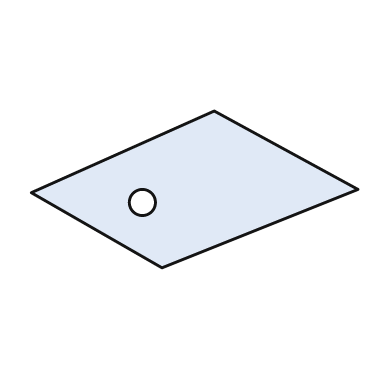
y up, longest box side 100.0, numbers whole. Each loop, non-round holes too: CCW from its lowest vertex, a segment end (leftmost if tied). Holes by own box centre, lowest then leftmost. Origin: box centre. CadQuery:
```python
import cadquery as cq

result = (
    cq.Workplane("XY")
    .moveTo(-10.0, -24.0)
    .lineTo(50.0, 0.0)
    .lineTo(6.0, 24.0)
    .lineTo(-50.0, -1.0)
    .close()
    .moveTo(-16.0, -4.0)
    .circle(4.0)
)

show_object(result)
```